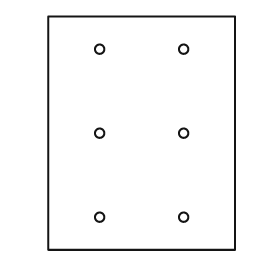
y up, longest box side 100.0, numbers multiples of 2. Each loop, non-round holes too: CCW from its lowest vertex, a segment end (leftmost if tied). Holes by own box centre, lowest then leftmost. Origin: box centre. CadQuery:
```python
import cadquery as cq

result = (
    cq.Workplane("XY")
    .moveTo(-40.0, -50.0)
    .lineTo(40.0, -50.0)
    .lineTo(40.0, 50.0)
    .lineTo(-40.0, 50.0)
    .close()
    .moveTo(-18.0, -36.0)
    .circle(2.0)
    .moveTo(18.0, -36.0)
    .circle(2.0)
    .moveTo(-18.0, 0.0)
    .circle(2.0)
    .moveTo(18.0, 0.0)
    .circle(2.0)
    .moveTo(-18.0, 36.0)
    .circle(2.0)
    .moveTo(18.0, 36.0)
    .circle(2.0)
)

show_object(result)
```